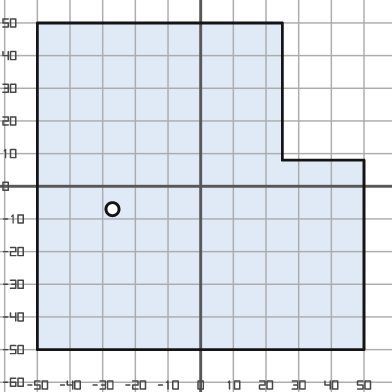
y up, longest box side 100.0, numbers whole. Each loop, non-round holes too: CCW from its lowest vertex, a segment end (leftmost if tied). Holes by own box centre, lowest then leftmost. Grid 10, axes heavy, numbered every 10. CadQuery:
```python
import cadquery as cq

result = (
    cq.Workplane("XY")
    .moveTo(-50.0, -50.0)
    .lineTo(50.0, -50.0)
    .lineTo(50.0, 8.0)
    .lineTo(25.0, 8.0)
    .lineTo(25.0, 50.0)
    .lineTo(-50.0, 50.0)
    .close()
    .moveTo(-27.0, -7.0)
    .circle(2.0)
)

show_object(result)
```